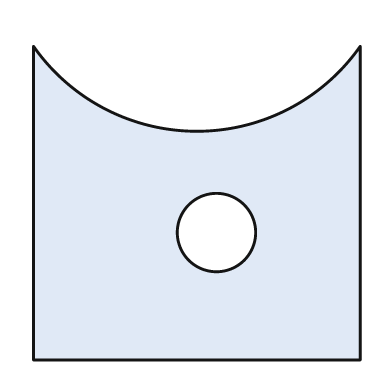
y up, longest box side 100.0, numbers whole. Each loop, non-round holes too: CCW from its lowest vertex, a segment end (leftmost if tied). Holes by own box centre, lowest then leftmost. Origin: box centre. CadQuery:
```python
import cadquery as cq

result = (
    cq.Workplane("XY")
    .moveTo(-50.0, -48.0)
    .lineTo(50.0, -48.0)
    .lineTo(50.0, 48.0)
    .threePointArc((0.0, 22.0), (-50.0, 48.0))
    .close()
    .moveTo(6.0, -9.0)
    .circle(12.0)
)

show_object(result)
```